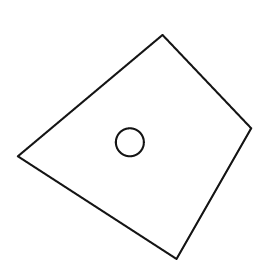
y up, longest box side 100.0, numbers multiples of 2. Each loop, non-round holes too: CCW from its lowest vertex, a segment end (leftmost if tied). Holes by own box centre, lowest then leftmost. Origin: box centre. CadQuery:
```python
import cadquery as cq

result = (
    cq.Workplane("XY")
    .moveTo(18.0, -48.0)
    .lineTo(50.0, 8.0)
    .lineTo(12.0, 48.0)
    .lineTo(-50.0, -4.0)
    .close()
    .moveTo(-2.0, 2.0)
    .circle(6.0)
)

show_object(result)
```